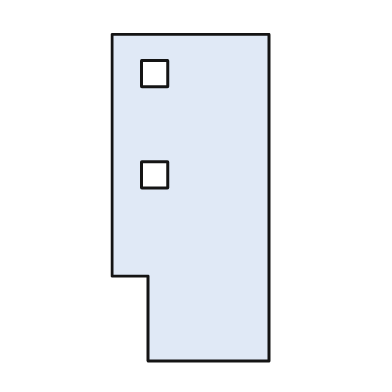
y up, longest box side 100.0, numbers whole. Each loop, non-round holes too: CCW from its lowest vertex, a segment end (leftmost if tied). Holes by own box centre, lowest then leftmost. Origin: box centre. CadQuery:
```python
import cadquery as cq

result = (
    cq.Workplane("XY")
    .moveTo(-13.0, -50.0)
    .lineTo(24.0, -50.0)
    .lineTo(24.0, 50.0)
    .lineTo(-24.0, 50.0)
    .lineTo(-24.0, -24.0)
    .lineTo(-13.0, -24.0)
    .close()
    .moveTo(-15.0, 3.0)
    .lineTo(-7.0, 3.0)
    .lineTo(-7.0, 11.0)
    .lineTo(-15.0, 11.0)
    .close()
    .moveTo(-15.0, 34.0)
    .lineTo(-7.0, 34.0)
    .lineTo(-7.0, 42.0)
    .lineTo(-15.0, 42.0)
    .close()
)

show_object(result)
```